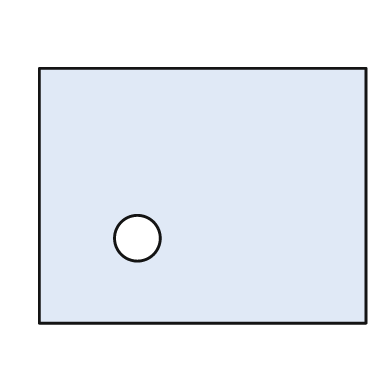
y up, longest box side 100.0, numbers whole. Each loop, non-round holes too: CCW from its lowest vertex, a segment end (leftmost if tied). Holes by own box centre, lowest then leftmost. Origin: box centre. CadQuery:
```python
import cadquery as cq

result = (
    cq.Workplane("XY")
    .moveTo(-50.0, -39.0)
    .lineTo(50.0, -39.0)
    .lineTo(50.0, 39.0)
    .lineTo(-50.0, 39.0)
    .close()
    .moveTo(-20.0, -13.0)
    .circle(7.0)
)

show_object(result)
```